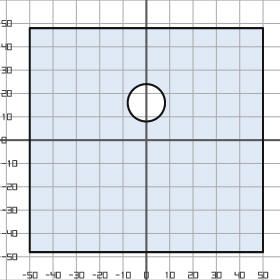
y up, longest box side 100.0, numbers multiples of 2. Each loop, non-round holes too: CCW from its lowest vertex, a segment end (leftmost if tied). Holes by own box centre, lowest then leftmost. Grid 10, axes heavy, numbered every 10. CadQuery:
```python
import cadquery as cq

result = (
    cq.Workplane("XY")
    .moveTo(-50.0, -48.0)
    .lineTo(50.0, -48.0)
    .lineTo(50.0, 48.0)
    .lineTo(-50.0, 48.0)
    .close()
    .moveTo(0.0, 16.0)
    .circle(8.0)
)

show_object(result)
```